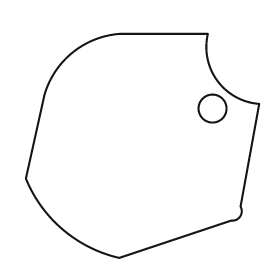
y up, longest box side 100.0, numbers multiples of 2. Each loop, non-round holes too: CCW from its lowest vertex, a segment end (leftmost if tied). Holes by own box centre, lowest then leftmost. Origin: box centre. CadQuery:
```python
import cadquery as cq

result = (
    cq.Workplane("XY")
    .moveTo(-10.0, -48.0)
    .lineTo(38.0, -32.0)
    .threePointArc((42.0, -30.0), (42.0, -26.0))
    .lineTo(50.0, 18.0)
    .threePointArc((32.0, 28.0), (28.0, 48.0))
    .lineTo(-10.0, 48.0)
    .threePointArc((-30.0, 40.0), (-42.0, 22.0))
    .lineTo(-50.0, -14.0)
    .threePointArc((-34.0, -36.0), (-10.0, -48.0))
    .close()
    .moveTo(30.0, 16.0)
    .circle(6.0)
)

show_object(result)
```